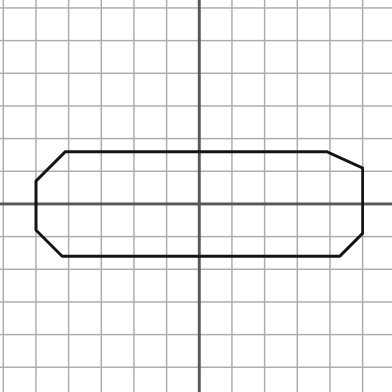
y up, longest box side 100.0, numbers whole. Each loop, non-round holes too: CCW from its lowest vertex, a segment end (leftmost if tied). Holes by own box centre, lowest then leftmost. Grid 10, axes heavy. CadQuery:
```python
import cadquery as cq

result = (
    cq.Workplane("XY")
    .moveTo(-42.0, -16.0)
    .lineTo(43.0, -16.0)
    .lineTo(50.0, -9.0)
    .lineTo(50.0, 11.0)
    .lineTo(39.0, 16.0)
    .lineTo(-41.0, 16.0)
    .lineTo(-50.0, 7.0)
    .lineTo(-50.0, -8.0)
    .close()
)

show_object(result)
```